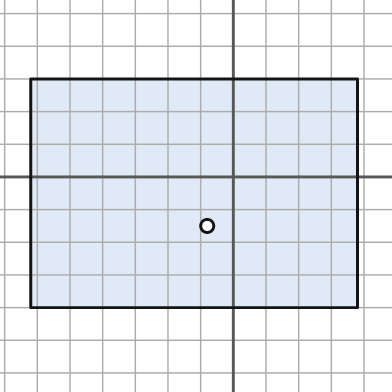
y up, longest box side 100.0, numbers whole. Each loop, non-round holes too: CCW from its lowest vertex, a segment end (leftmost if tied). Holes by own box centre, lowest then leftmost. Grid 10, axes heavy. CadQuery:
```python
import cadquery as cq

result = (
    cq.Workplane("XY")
    .moveTo(-62.0, -40.0)
    .lineTo(38.0, -40.0)
    .lineTo(38.0, 30.0)
    .lineTo(-62.0, 30.0)
    .close()
    .moveTo(-8.0, -15.0)
    .circle(2.0)
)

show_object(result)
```